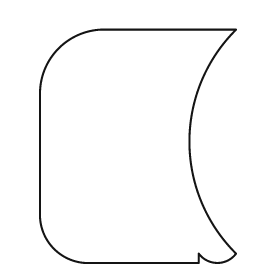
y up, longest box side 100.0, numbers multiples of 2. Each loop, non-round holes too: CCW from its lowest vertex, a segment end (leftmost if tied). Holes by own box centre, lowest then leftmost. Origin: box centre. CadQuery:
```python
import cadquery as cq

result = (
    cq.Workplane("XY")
    .moveTo(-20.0, -50.0)
    .lineTo(26.0, -50.0)
    .lineTo(26.0, -46.0)
    .threePointArc((34.0, -50.0), (42.0, -46.0))
    .threePointArc((22.0, 2.0), (42.0, 50.0))
    .lineTo(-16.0, 50.0)
    .threePointArc((-34.0, 42.0), (-42.0, 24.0))
    .lineTo(-42.0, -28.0)
    .threePointArc((-36.0, -44.0), (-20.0, -50.0))
    .close()
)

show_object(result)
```